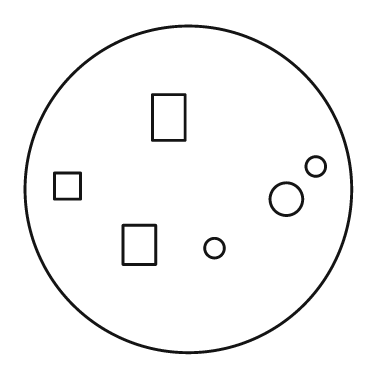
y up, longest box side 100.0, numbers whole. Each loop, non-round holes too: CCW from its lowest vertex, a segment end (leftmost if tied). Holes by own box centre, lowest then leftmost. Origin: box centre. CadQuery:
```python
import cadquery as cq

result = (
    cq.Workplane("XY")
    .moveTo(0.0, 0.0)
    .circle(50.0)
    .moveTo(8.0, -18.0)
    .circle(3.0)
    .moveTo(-20.0, -23.0)
    .lineTo(-10.0, -23.0)
    .lineTo(-10.0, -11.0)
    .lineTo(-20.0, -11.0)
    .close()
    .moveTo(30.0, -3.0)
    .circle(5.0)
    .moveTo(-41.0, -3.0)
    .lineTo(-33.0, -3.0)
    .lineTo(-33.0, 5.0)
    .lineTo(-41.0, 5.0)
    .close()
    .moveTo(39.0, 7.0)
    .circle(3.0)
    .moveTo(-11.0, 15.0)
    .lineTo(-1.0, 15.0)
    .lineTo(-1.0, 29.0)
    .lineTo(-11.0, 29.0)
    .close()
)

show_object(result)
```